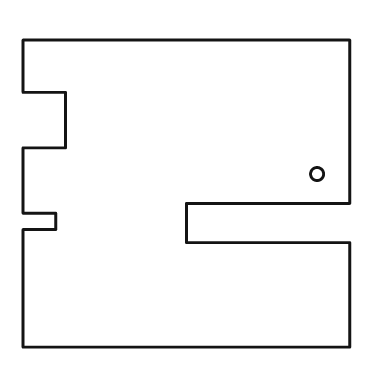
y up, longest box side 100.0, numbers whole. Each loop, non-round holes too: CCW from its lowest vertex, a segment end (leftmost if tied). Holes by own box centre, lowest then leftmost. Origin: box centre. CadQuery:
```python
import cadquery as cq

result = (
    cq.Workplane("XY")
    .moveTo(-50.0, -47.0)
    .lineTo(50.0, -47.0)
    .lineTo(50.0, -15.0)
    .lineTo(0.0, -15.0)
    .lineTo(0.0, -3.0)
    .lineTo(50.0, -3.0)
    .lineTo(50.0, 47.0)
    .lineTo(-50.0, 47.0)
    .lineTo(-50.0, 31.0)
    .lineTo(-37.0, 31.0)
    .lineTo(-37.0, 14.0)
    .lineTo(-50.0, 14.0)
    .lineTo(-50.0, -6.0)
    .lineTo(-40.0, -6.0)
    .lineTo(-40.0, -11.0)
    .lineTo(-50.0, -11.0)
    .close()
    .moveTo(40.0, 6.0)
    .circle(2.0)
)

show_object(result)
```